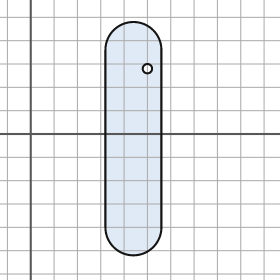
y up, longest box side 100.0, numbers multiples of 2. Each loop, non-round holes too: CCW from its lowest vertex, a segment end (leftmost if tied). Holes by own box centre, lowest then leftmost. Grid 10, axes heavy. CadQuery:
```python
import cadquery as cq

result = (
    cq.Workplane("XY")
    .moveTo(32.0, -40.0)
    .threePointArc((44.0, -52.0), (56.0, -40.0))
    .lineTo(56.0, 36.0)
    .threePointArc((44.0, 48.0), (32.0, 36.0))
    .close()
    .moveTo(50.0, 28.0)
    .circle(2.0)
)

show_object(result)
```